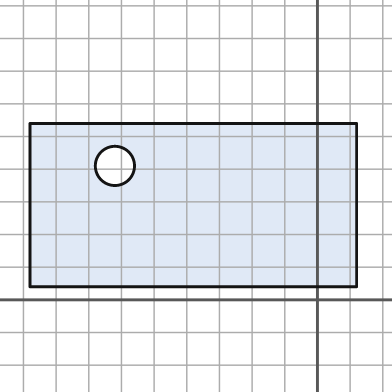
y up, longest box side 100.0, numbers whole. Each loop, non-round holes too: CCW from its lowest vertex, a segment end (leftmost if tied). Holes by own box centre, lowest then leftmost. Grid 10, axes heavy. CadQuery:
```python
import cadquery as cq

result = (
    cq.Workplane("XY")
    .moveTo(-88.0, 4.0)
    .lineTo(12.0, 4.0)
    .lineTo(12.0, 54.0)
    .lineTo(-88.0, 54.0)
    .close()
    .moveTo(-62.0, 41.0)
    .circle(6.0)
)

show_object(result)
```